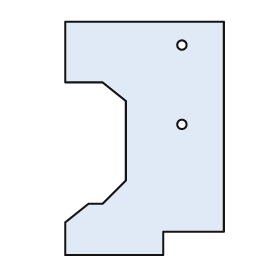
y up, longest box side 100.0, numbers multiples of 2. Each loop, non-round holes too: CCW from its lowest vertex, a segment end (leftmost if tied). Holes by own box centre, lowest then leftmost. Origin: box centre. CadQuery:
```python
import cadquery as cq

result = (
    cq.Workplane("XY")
    .moveTo(-34.0, -50.0)
    .lineTo(8.0, -50.0)
    .lineTo(8.0, -40.0)
    .lineTo(34.0, -40.0)
    .lineTo(34.0, 50.0)
    .lineTo(-34.0, 50.0)
    .lineTo(-34.0, 24.0)
    .lineTo(-18.0, 24.0)
    .lineTo(-8.0, 16.0)
    .lineTo(-8.0, -18.0)
    .lineTo(-18.0, -28.0)
    .lineTo(-24.0, -28.0)
    .lineTo(-34.0, -36.0)
    .close()
    .moveTo(16.0, 6.0)
    .circle(2.0)
    .moveTo(16.0, 40.0)
    .circle(2.0)
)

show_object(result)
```